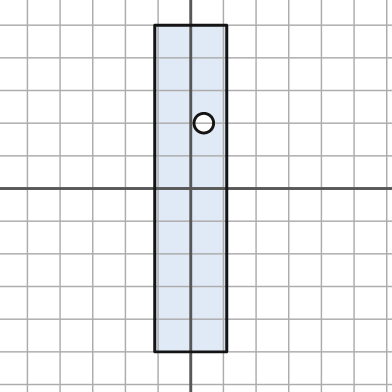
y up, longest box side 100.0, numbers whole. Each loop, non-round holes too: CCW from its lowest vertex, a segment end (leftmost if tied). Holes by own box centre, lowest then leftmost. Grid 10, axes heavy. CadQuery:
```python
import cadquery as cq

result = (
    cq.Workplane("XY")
    .moveTo(-11.0, -50.0)
    .lineTo(11.0, -50.0)
    .lineTo(11.0, 50.0)
    .lineTo(-11.0, 50.0)
    .close()
    .moveTo(4.0, 20.0)
    .circle(3.0)
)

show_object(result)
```